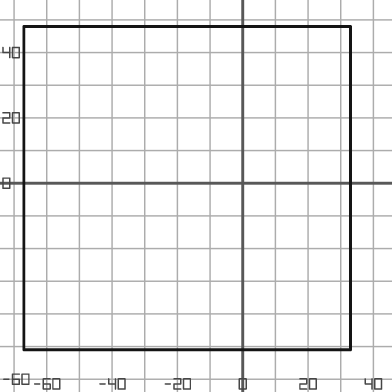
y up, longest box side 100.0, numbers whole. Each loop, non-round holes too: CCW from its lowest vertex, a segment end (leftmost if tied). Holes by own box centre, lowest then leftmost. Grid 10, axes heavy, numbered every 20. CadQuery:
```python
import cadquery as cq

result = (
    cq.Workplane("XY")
    .moveTo(-67.0, -51.0)
    .lineTo(33.0, -51.0)
    .lineTo(33.0, 48.0)
    .lineTo(-67.0, 48.0)
    .close()
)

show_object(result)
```